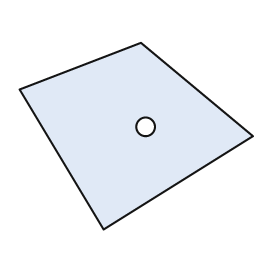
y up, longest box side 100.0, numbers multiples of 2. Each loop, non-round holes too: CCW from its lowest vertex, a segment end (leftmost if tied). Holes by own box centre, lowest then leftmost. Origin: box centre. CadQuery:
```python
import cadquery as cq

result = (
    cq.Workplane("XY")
    .moveTo(-14.0, -40.0)
    .lineTo(50.0, 0.0)
    .lineTo(2.0, 40.0)
    .lineTo(-50.0, 20.0)
    .close()
    .moveTo(4.0, 4.0)
    .circle(4.0)
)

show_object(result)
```